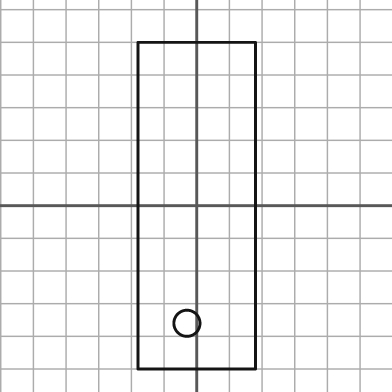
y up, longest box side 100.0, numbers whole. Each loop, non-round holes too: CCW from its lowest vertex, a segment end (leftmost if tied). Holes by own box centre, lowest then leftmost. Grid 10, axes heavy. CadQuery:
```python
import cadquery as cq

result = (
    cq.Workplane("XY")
    .moveTo(-18.0, -50.0)
    .lineTo(18.0, -50.0)
    .lineTo(18.0, 50.0)
    .lineTo(-18.0, 50.0)
    .close()
    .moveTo(-3.0, -36.0)
    .circle(4.0)
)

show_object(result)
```